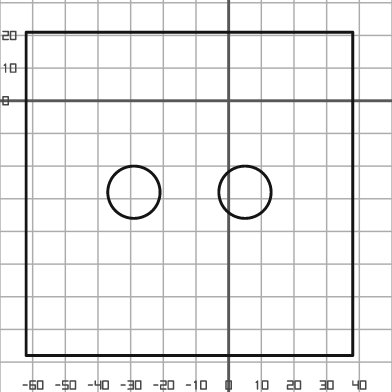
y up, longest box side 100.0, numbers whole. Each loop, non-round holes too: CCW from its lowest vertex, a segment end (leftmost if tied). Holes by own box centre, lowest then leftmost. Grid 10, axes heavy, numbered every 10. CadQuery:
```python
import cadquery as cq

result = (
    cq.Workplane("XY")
    .moveTo(-62.0, -78.0)
    .lineTo(38.0, -78.0)
    .lineTo(38.0, 21.0)
    .lineTo(-62.0, 21.0)
    .close()
    .moveTo(-29.0, -28.0)
    .circle(8.0)
    .moveTo(5.0, -28.0)
    .circle(8.0)
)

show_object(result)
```